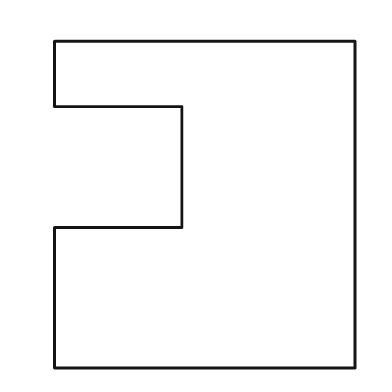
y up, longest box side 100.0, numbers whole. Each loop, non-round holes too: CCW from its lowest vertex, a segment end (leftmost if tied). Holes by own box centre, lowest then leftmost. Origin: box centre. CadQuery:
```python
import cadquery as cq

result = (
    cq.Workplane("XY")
    .moveTo(-46.0, -50.0)
    .lineTo(46.0, -50.0)
    .lineTo(46.0, 50.0)
    .lineTo(-46.0, 50.0)
    .lineTo(-46.0, 30.0)
    .lineTo(-7.0, 30.0)
    .lineTo(-7.0, -7.0)
    .lineTo(-46.0, -7.0)
    .close()
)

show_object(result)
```